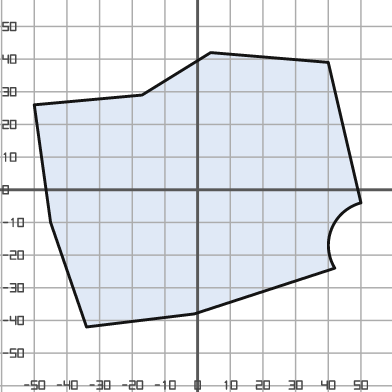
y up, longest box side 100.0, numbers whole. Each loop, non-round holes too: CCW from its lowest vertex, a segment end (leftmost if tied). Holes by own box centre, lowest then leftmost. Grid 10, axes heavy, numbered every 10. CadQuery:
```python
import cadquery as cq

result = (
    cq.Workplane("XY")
    .moveTo(-34.0, -42.0)
    .lineTo(-1.0, -38.0)
    .lineTo(42.0, -24.0)
    .threePointArc((41.0, -12.0), (50.0, -4.0))
    .lineTo(40.0, 39.0)
    .lineTo(4.0, 42.0)
    .lineTo(-17.0, 29.0)
    .lineTo(-50.0, 26.0)
    .lineTo(-45.0, -10.0)
    .close()
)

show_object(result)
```